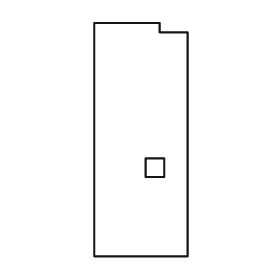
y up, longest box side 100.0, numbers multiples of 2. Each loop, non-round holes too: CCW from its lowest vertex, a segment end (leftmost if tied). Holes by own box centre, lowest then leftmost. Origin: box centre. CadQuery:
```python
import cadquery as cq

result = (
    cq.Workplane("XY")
    .moveTo(-20.0, -50.0)
    .lineTo(20.0, -50.0)
    .lineTo(20.0, 46.0)
    .lineTo(8.0, 46.0)
    .lineTo(8.0, 50.0)
    .lineTo(-20.0, 50.0)
    .close()
    .moveTo(2.0, -16.0)
    .lineTo(10.0, -16.0)
    .lineTo(10.0, -8.0)
    .lineTo(2.0, -8.0)
    .close()
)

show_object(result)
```